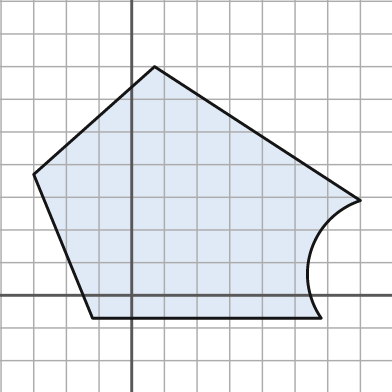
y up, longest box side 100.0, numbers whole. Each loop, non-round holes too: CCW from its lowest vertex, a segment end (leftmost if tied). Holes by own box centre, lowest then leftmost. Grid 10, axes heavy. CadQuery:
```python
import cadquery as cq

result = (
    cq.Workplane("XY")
    .moveTo(-12.0, -7.0)
    .lineTo(58.0, -7.0)
    .threePointArc((55.0, 14.0), (70.0, 29.0))
    .lineTo(7.0, 70.0)
    .lineTo(-30.0, 37.0)
    .close()
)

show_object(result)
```